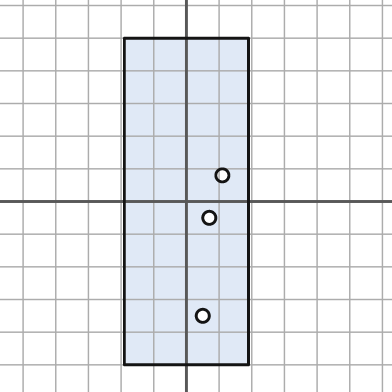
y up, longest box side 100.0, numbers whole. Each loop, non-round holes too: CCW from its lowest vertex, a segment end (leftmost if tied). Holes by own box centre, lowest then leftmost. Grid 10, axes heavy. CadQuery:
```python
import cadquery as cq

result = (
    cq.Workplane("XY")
    .moveTo(-19.0, -50.0)
    .lineTo(19.0, -50.0)
    .lineTo(19.0, 50.0)
    .lineTo(-19.0, 50.0)
    .close()
    .moveTo(5.0, -35.0)
    .circle(2.0)
    .moveTo(7.0, -5.0)
    .circle(2.0)
    .moveTo(11.0, 8.0)
    .circle(2.0)
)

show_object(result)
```